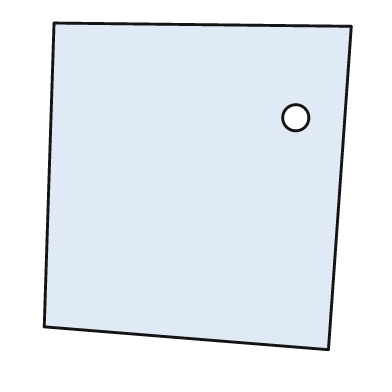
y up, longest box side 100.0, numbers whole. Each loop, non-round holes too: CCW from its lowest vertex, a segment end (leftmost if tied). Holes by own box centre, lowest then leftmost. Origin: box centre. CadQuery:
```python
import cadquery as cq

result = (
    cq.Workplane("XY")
    .moveTo(40.0, -50.0)
    .lineTo(47.0, 49.0)
    .lineTo(-44.0, 50.0)
    .lineTo(-47.0, -43.0)
    .close()
    .moveTo(30.0, 21.0)
    .circle(4.0)
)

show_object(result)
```